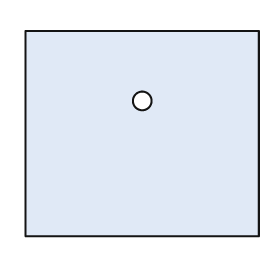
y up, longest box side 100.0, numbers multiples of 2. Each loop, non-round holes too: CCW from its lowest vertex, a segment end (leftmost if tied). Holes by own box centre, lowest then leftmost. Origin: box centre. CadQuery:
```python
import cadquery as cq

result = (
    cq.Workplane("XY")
    .moveTo(-50.0, -44.0)
    .lineTo(50.0, -44.0)
    .lineTo(50.0, 44.0)
    .lineTo(-50.0, 44.0)
    .close()
    .moveTo(0.0, 14.0)
    .circle(4.0)
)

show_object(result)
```